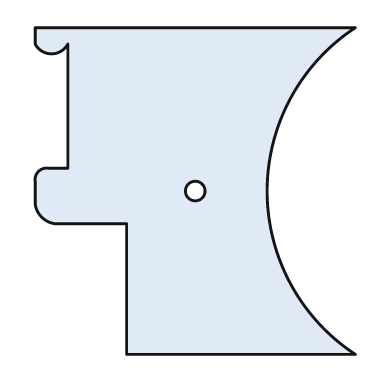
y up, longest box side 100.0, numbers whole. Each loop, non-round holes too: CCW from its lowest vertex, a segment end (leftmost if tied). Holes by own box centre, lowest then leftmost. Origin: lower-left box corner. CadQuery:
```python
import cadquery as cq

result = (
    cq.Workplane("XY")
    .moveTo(28.0, 0.0)
    .lineTo(98.0, 0.0)
    .threePointArc((71.0, 50.0), (98.0, 100.0))
    .lineTo(0.0, 100.0)
    .lineTo(0.0, 95.0)
    .threePointArc((5.0, 92.0), (10.0, 95.0))
    .lineTo(10.0, 57.0)
    .lineTo(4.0, 57.0)
    .threePointArc((1.0, 56.0), (0.0, 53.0))
    .lineTo(0.0, 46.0)
    .threePointArc((2.0, 42.0), (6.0, 40.0))
    .lineTo(28.0, 40.0)
    .close()
    .moveTo(49.0, 50.0)
    .circle(3.0)
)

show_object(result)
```